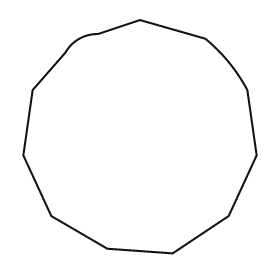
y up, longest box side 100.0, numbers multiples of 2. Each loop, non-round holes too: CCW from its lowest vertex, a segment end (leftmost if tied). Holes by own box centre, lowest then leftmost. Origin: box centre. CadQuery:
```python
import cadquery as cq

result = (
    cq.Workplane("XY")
    .moveTo(14.0, -50.0)
    .lineTo(38.0, -34.0)
    .lineTo(50.0, -8.0)
    .lineTo(46.0, 20.0)
    .threePointArc((38.0, 32.0), (28.0, 42.0))
    .lineTo(0.0, 50.0)
    .lineTo(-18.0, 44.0)
    .threePointArc((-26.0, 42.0), (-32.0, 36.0))
    .lineTo(-46.0, 20.0)
    .lineTo(-50.0, -8.0)
    .lineTo(-38.0, -34.0)
    .lineTo(-14.0, -48.0)
    .close()
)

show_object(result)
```